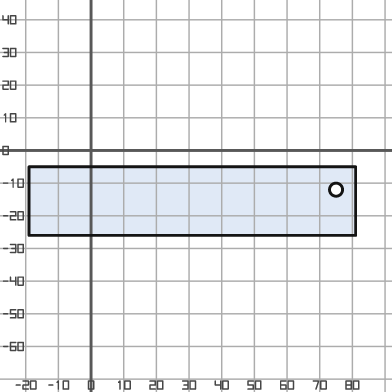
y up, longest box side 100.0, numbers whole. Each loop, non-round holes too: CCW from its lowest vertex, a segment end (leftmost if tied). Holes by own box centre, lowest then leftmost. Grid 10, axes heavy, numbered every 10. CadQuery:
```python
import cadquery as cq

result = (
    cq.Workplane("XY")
    .moveTo(-19.0, -26.0)
    .lineTo(81.0, -26.0)
    .lineTo(81.0, -5.0)
    .lineTo(-19.0, -5.0)
    .close()
    .moveTo(75.0, -12.0)
    .circle(2.0)
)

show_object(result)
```